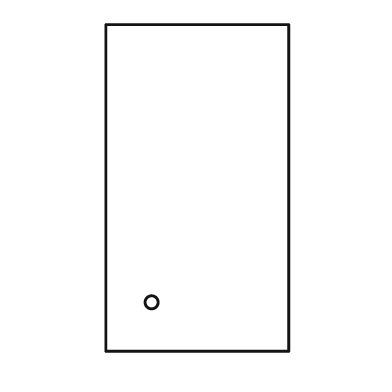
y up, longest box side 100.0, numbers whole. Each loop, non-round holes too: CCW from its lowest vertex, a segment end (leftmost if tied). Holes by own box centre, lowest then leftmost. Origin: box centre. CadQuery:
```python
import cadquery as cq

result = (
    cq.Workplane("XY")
    .moveTo(-28.0, -50.0)
    .lineTo(28.0, -50.0)
    .lineTo(28.0, 50.0)
    .lineTo(-28.0, 50.0)
    .close()
    .moveTo(-14.0, -35.0)
    .circle(2.0)
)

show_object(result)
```